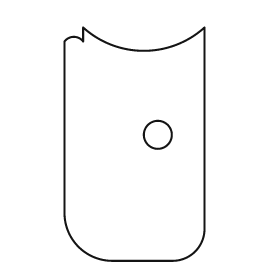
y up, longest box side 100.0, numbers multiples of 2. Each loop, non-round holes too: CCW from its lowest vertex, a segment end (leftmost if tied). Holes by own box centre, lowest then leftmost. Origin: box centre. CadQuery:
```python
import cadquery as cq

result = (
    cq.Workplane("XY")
    .moveTo(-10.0, -50.0)
    .lineTo(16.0, -50.0)
    .threePointArc((26.0, -46.0), (30.0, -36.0))
    .lineTo(30.0, 50.0)
    .threePointArc((4.0, 40.0), (-22.0, 50.0))
    .lineTo(-22.0, 44.0)
    .threePointArc((-26.0, 46.0), (-30.0, 44.0))
    .lineTo(-30.0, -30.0)
    .threePointArc((-24.0, -44.0), (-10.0, -50.0))
    .close()
    .moveTo(10.0, 4.0)
    .circle(6.0)
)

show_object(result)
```